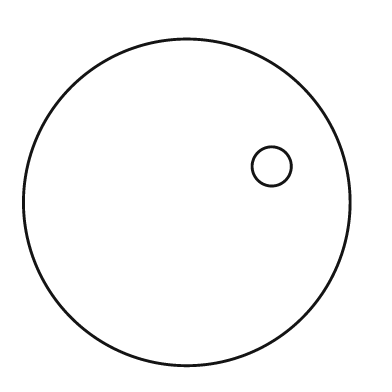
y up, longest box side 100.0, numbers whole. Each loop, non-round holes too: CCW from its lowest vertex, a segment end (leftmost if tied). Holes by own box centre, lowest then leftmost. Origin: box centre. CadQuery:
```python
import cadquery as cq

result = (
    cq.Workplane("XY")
    .moveTo(0.0, 0.0)
    .circle(50.0)
    .moveTo(26.0, 11.0)
    .circle(6.0)
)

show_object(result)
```